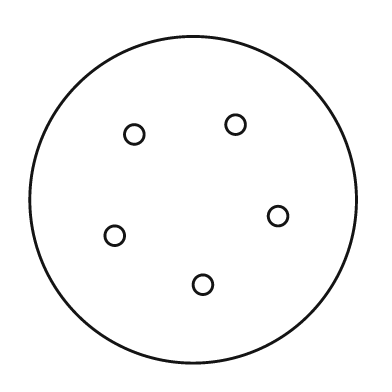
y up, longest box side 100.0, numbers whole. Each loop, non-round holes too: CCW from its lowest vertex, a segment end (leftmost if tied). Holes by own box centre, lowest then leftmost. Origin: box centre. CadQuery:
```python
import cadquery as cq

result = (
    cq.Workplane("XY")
    .moveTo(0.0, 0.0)
    .circle(50.0)
    .moveTo(3.0, -26.0)
    .circle(3.0)
    .moveTo(-24.0, -11.0)
    .circle(3.0)
    .moveTo(26.0, -5.0)
    .circle(3.0)
    .moveTo(-18.0, 20.0)
    .circle(3.0)
    .moveTo(13.0, 23.0)
    .circle(3.0)
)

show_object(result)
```